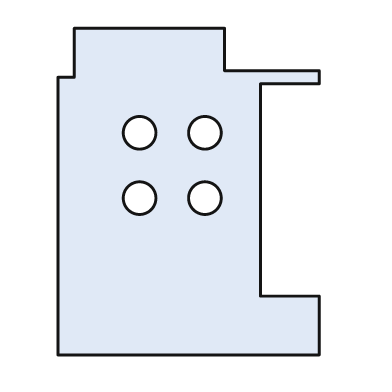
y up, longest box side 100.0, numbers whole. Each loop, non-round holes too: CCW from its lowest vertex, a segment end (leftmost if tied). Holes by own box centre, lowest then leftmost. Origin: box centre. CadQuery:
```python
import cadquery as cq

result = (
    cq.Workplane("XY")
    .moveTo(-40.0, -50.0)
    .lineTo(40.0, -50.0)
    .lineTo(40.0, -32.0)
    .lineTo(22.0, -32.0)
    .lineTo(22.0, 33.0)
    .lineTo(40.0, 33.0)
    .lineTo(40.0, 37.0)
    .lineTo(11.0, 37.0)
    .lineTo(11.0, 50.0)
    .lineTo(-35.0, 50.0)
    .lineTo(-35.0, 35.0)
    .lineTo(-40.0, 35.0)
    .close()
    .moveTo(-15.0, -2.0)
    .circle(5.0)
    .moveTo(5.0, -2.0)
    .circle(5.0)
    .moveTo(-15.0, 18.0)
    .circle(5.0)
    .moveTo(5.0, 18.0)
    .circle(5.0)
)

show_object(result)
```